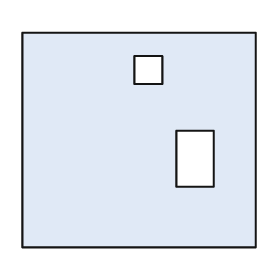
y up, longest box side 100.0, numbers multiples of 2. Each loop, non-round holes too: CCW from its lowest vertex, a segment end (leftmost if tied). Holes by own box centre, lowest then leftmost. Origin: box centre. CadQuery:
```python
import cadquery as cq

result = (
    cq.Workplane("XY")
    .moveTo(-50.0, -46.0)
    .lineTo(50.0, -46.0)
    .lineTo(50.0, 46.0)
    .lineTo(-50.0, 46.0)
    .close()
    .moveTo(16.0, -20.0)
    .lineTo(32.0, -20.0)
    .lineTo(32.0, 4.0)
    .lineTo(16.0, 4.0)
    .close()
    .moveTo(-2.0, 24.0)
    .lineTo(10.0, 24.0)
    .lineTo(10.0, 36.0)
    .lineTo(-2.0, 36.0)
    .close()
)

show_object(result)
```